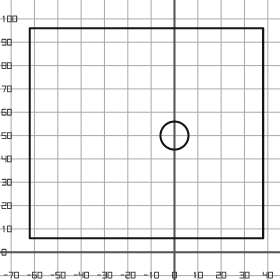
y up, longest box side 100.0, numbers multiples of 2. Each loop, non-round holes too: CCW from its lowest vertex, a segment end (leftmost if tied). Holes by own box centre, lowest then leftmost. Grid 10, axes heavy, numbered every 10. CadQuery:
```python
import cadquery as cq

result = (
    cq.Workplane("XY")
    .moveTo(-62.0, 6.0)
    .lineTo(38.0, 6.0)
    .lineTo(38.0, 96.0)
    .lineTo(-62.0, 96.0)
    .close()
    .moveTo(0.0, 50.0)
    .circle(6.0)
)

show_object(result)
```